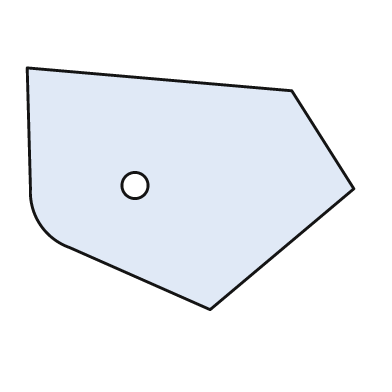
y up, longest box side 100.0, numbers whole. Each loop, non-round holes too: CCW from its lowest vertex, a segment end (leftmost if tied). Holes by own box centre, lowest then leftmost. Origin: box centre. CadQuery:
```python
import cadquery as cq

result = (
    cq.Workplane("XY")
    .moveTo(6.0, -37.0)
    .lineTo(50.0, 0.0)
    .lineTo(31.0, 30.0)
    .lineTo(-50.0, 37.0)
    .lineTo(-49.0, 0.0)
    .threePointArc((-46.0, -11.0), (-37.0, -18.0))
    .close()
    .moveTo(-17.0, 1.0)
    .circle(4.0)
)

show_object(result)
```